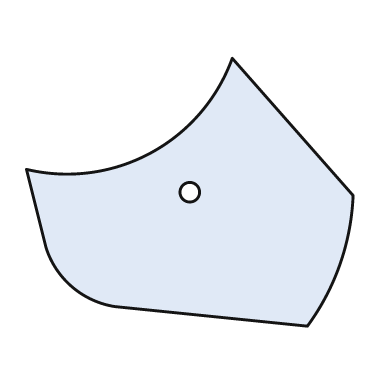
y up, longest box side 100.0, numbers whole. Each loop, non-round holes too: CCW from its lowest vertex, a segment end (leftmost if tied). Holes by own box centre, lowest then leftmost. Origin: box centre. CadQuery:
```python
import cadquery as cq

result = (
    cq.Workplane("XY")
    .moveTo(36.0, -41.0)
    .threePointArc((46.0, -22.0), (50.0, -1.0))
    .lineTo(13.0, 41.0)
    .threePointArc((-12.0, 12.0), (-50.0, 7.0))
    .lineTo(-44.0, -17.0)
    .threePointArc((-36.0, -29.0), (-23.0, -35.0))
    .close()
    .moveTo(0.0, 0.0)
    .circle(3.0)
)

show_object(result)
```